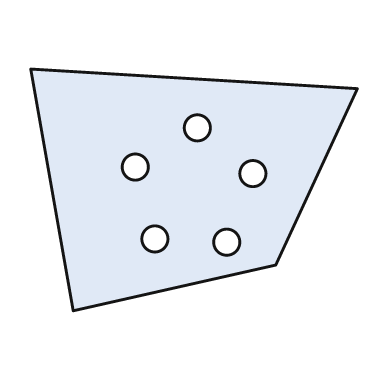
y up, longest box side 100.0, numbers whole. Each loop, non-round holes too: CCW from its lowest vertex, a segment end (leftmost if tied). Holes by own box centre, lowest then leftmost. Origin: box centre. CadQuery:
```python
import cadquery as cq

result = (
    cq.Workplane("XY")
    .moveTo(-37.0, -37.0)
    .lineTo(25.0, -23.0)
    .lineTo(50.0, 31.0)
    .lineTo(-50.0, 37.0)
    .close()
    .moveTo(10.0, -16.0)
    .circle(4.0)
    .moveTo(-12.0, -15.0)
    .circle(4.0)
    .moveTo(18.0, 5.0)
    .circle(4.0)
    .moveTo(-18.0, 7.0)
    .circle(4.0)
    .moveTo(1.0, 19.0)
    .circle(4.0)
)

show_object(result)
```